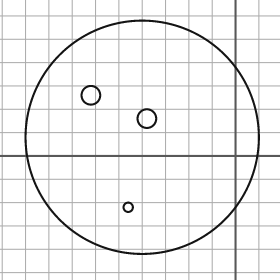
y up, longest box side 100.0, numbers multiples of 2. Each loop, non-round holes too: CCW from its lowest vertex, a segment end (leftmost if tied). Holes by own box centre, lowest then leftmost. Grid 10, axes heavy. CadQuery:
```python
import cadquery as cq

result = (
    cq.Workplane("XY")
    .moveTo(-40.0, 8.0)
    .circle(50.0)
    .moveTo(-46.0, -22.0)
    .circle(2.0)
    .moveTo(-38.0, 16.0)
    .circle(4.0)
    .moveTo(-62.0, 26.0)
    .circle(4.0)
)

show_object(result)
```